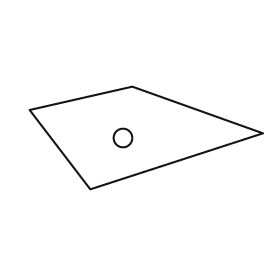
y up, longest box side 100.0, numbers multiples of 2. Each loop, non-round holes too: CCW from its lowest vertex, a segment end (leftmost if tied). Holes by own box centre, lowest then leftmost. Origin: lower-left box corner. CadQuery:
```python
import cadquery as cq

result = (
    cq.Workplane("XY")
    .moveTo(26.0, 0.0)
    .lineTo(100.0, 24.0)
    .lineTo(44.0, 44.0)
    .lineTo(0.0, 34.0)
    .close()
    .moveTo(40.0, 22.0)
    .circle(4.0)
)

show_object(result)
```